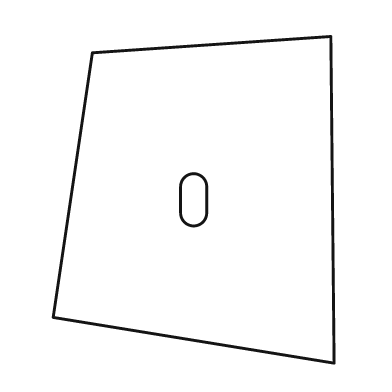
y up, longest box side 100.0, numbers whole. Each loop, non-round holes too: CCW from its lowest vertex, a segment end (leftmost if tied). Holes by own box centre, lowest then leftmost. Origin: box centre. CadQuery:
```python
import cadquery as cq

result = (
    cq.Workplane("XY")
    .moveTo(43.0, -50.0)
    .lineTo(42.0, 50.0)
    .lineTo(-31.0, 45.0)
    .lineTo(-43.0, -36.0)
    .close()
    .moveTo(-4.0, -4.0)
    .threePointArc((0.0, -8.0), (4.0, -4.0))
    .lineTo(4.0, 4.0)
    .threePointArc((0.0, 8.0), (-4.0, 4.0))
    .close()
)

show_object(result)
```